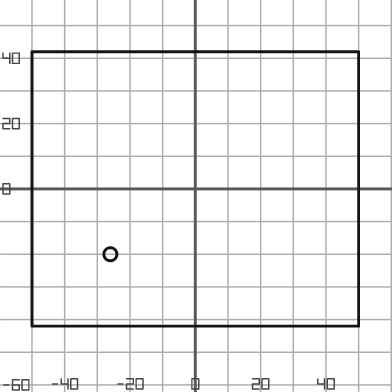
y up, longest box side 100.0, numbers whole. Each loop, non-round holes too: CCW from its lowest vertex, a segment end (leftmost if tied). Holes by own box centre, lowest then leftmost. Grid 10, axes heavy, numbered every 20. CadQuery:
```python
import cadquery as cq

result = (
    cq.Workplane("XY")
    .moveTo(-50.0, -42.0)
    .lineTo(50.0, -42.0)
    .lineTo(50.0, 42.0)
    .lineTo(-50.0, 42.0)
    .close()
    .moveTo(-26.0, -20.0)
    .circle(2.0)
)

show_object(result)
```